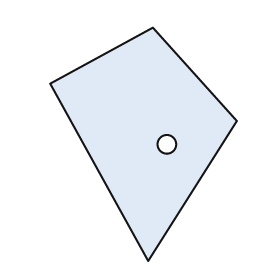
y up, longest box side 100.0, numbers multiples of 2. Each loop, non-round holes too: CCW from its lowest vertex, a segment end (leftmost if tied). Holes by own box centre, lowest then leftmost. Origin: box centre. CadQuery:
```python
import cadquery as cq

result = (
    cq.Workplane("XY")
    .moveTo(2.0, -50.0)
    .lineTo(40.0, 10.0)
    .lineTo(4.0, 50.0)
    .lineTo(-40.0, 26.0)
    .close()
    .moveTo(10.0, 0.0)
    .circle(4.0)
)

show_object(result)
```